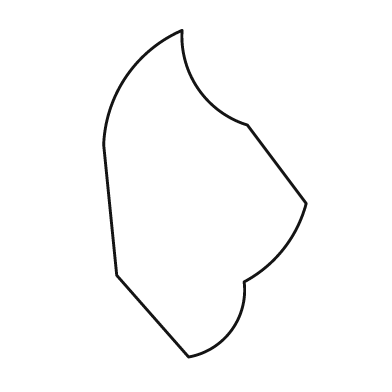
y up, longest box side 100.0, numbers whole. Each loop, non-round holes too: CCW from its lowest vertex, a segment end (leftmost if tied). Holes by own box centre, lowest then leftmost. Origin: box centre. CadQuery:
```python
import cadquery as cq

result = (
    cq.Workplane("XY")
    .moveTo(-5.0, -50.0)
    .threePointArc((8.0, -42.0), (12.0, -27.0))
    .threePointArc((24.0, -17.0), (31.0, -3.0))
    .lineTo(13.0, 21.0)
    .threePointArc((-2.0, 32.0), (-7.0, 50.0))
    .threePointArc((-24.0, 36.0), (-31.0, 15.0))
    .lineTo(-27.0, -25.0)
    .close()
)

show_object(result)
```